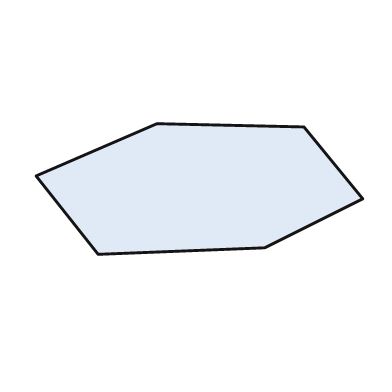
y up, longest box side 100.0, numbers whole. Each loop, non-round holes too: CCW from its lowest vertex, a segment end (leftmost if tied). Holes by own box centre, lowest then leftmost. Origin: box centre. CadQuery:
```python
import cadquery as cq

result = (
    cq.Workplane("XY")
    .moveTo(-31.0, -20.0)
    .lineTo(20.0, -18.0)
    .lineTo(50.0, -3.0)
    .lineTo(32.0, 19.0)
    .lineTo(-13.0, 20.0)
    .lineTo(-50.0, 4.0)
    .close()
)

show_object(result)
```